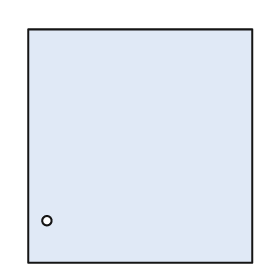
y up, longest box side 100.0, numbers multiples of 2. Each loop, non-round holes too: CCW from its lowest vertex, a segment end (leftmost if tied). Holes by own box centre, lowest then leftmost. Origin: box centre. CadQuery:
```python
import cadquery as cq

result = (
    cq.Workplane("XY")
    .moveTo(-48.0, -50.0)
    .lineTo(48.0, -50.0)
    .lineTo(48.0, 50.0)
    .lineTo(-48.0, 50.0)
    .close()
    .moveTo(-40.0, -32.0)
    .circle(2.0)
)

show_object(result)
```